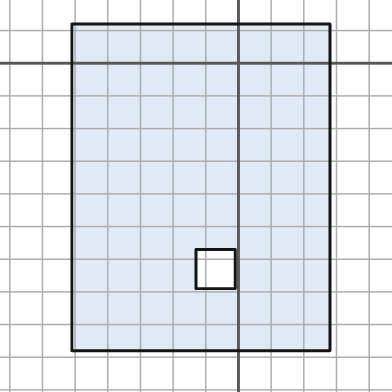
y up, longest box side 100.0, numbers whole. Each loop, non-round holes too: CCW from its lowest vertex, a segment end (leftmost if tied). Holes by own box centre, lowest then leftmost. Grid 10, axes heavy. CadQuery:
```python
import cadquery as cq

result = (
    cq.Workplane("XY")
    .moveTo(-51.0, -88.0)
    .lineTo(28.0, -88.0)
    .lineTo(28.0, 12.0)
    .lineTo(-51.0, 12.0)
    .close()
    .moveTo(-13.0, -69.0)
    .lineTo(-1.0, -69.0)
    .lineTo(-1.0, -57.0)
    .lineTo(-13.0, -57.0)
    .close()
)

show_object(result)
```